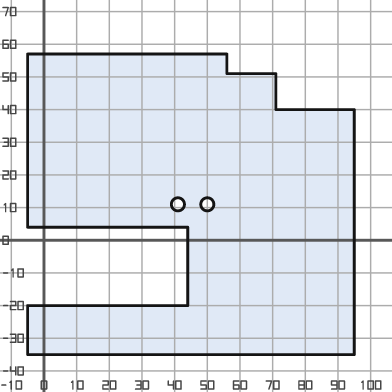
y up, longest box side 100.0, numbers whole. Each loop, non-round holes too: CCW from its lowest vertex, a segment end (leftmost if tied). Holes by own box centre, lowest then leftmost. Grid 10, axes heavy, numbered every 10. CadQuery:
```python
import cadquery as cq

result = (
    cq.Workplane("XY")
    .moveTo(-5.0, -35.0)
    .lineTo(95.0, -35.0)
    .lineTo(95.0, 40.0)
    .lineTo(71.0, 40.0)
    .lineTo(71.0, 51.0)
    .lineTo(56.0, 51.0)
    .lineTo(56.0, 57.0)
    .lineTo(-5.0, 57.0)
    .lineTo(-5.0, 4.0)
    .lineTo(44.0, 4.0)
    .lineTo(44.0, -20.0)
    .lineTo(-5.0, -20.0)
    .close()
    .moveTo(41.0, 11.0)
    .circle(2.0)
    .moveTo(50.0, 11.0)
    .circle(2.0)
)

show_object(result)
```